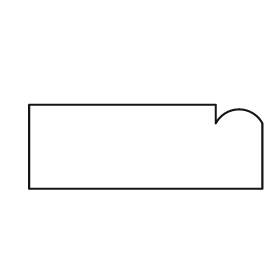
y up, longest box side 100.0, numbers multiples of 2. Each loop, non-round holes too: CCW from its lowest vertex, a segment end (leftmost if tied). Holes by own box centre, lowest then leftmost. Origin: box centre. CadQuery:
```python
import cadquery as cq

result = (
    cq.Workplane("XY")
    .moveTo(-50.0, -18.0)
    .lineTo(50.0, -18.0)
    .lineTo(50.0, 10.0)
    .threePointArc((40.0, 16.0), (30.0, 10.0))
    .lineTo(30.0, 18.0)
    .lineTo(-50.0, 18.0)
    .close()
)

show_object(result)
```